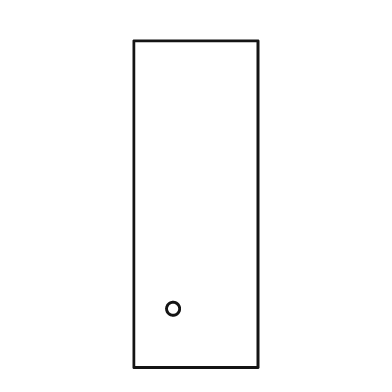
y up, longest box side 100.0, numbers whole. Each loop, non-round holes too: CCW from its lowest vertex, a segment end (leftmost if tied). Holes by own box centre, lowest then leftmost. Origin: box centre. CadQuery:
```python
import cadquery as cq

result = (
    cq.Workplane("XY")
    .moveTo(-19.0, -50.0)
    .lineTo(19.0, -50.0)
    .lineTo(19.0, 50.0)
    .lineTo(-19.0, 50.0)
    .close()
    .moveTo(-7.0, -32.0)
    .circle(2.0)
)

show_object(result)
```